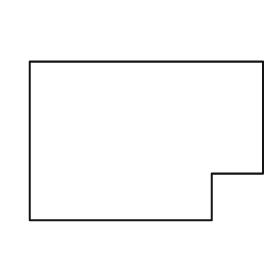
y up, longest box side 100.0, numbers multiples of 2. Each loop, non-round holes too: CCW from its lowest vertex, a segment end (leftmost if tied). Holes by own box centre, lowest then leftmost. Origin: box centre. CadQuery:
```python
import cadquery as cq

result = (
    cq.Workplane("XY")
    .moveTo(-50.0, -34.0)
    .lineTo(28.0, -34.0)
    .lineTo(28.0, -14.0)
    .lineTo(50.0, -14.0)
    .lineTo(50.0, 34.0)
    .lineTo(-50.0, 34.0)
    .close()
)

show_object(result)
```